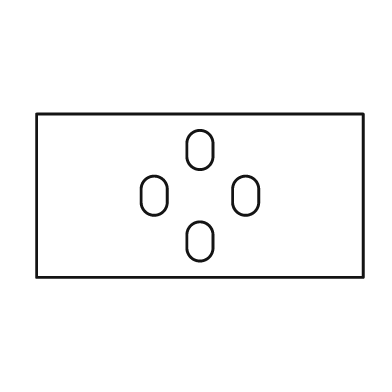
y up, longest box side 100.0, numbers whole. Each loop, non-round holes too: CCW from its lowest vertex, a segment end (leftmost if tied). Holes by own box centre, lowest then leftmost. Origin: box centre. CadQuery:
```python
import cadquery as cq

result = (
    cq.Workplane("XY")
    .moveTo(-50.0, -25.0)
    .lineTo(50.0, -25.0)
    .lineTo(50.0, 25.0)
    .lineTo(-50.0, 25.0)
    .close()
    .moveTo(-4.0, -16.0)
    .threePointArc((0.0, -20.0), (4.0, -16.0))
    .lineTo(4.0, -12.0)
    .threePointArc((0.0, -8.0), (-4.0, -12.0))
    .close()
    .moveTo(-18.0, -2.0)
    .threePointArc((-14.0, -6.0), (-10.0, -2.0))
    .lineTo(-10.0, 2.0)
    .threePointArc((-14.0, 6.0), (-18.0, 2.0))
    .close()
    .moveTo(10.0, -2.0)
    .threePointArc((14.0, -6.0), (18.0, -2.0))
    .lineTo(18.0, 2.0)
    .threePointArc((14.0, 6.0), (10.0, 2.0))
    .close()
    .moveTo(-4.0, 12.0)
    .threePointArc((0.0, 8.0), (4.0, 12.0))
    .lineTo(4.0, 16.0)
    .threePointArc((0.0, 20.0), (-4.0, 16.0))
    .close()
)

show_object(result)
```